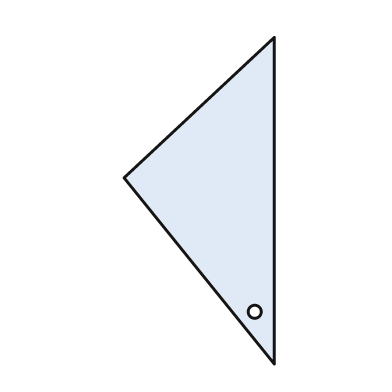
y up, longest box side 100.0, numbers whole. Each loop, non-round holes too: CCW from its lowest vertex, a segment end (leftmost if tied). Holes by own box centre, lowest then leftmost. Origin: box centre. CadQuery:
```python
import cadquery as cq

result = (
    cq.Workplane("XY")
    .moveTo(23.0, -50.0)
    .lineTo(23.0, 50.0)
    .lineTo(-23.0, 7.0)
    .close()
    .moveTo(17.0, -34.0)
    .circle(2.0)
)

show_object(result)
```